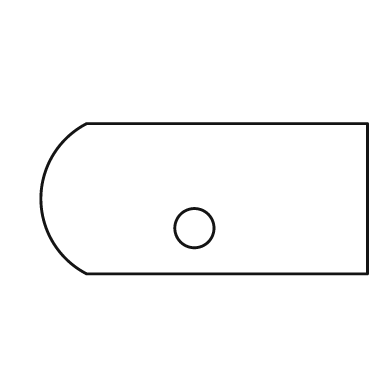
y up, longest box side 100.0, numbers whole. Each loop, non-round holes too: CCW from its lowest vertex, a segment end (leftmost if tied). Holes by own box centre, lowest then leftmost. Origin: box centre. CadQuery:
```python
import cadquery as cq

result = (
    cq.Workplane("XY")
    .moveTo(-36.0, -23.0)
    .lineTo(50.0, -23.0)
    .lineTo(50.0, 23.0)
    .lineTo(-36.0, 23.0)
    .threePointArc((-50.0, 0.0), (-36.0, -23.0))
    .close()
    .moveTo(-3.0, -9.0)
    .circle(6.0)
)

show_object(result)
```